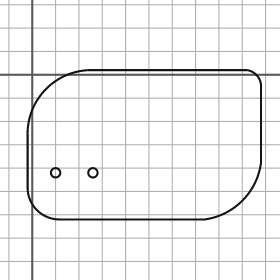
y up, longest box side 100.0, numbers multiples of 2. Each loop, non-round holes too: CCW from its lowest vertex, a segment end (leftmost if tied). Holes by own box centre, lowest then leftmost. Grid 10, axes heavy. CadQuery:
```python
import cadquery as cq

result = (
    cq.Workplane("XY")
    .moveTo(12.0, -62.0)
    .lineTo(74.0, -62.0)
    .threePointArc((90.0, -54.0), (98.0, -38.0))
    .lineTo(98.0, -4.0)
    .threePointArc((96.0, 0.0), (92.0, 2.0))
    .lineTo(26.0, 2.0)
    .threePointArc((6.0, -6.0), (-2.0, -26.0))
    .lineTo(-2.0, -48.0)
    .threePointArc((2.0, -58.0), (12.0, -62.0))
    .close()
    .moveTo(10.0, -42.0)
    .circle(2.0)
    .moveTo(26.0, -42.0)
    .circle(2.0)
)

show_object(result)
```